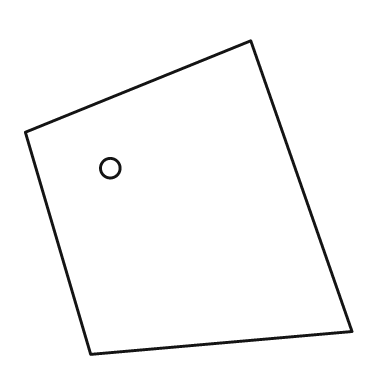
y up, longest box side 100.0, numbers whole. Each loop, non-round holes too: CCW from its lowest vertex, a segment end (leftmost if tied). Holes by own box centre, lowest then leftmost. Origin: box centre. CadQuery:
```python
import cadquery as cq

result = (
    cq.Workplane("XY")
    .moveTo(-30.0, -48.0)
    .lineTo(50.0, -41.0)
    .lineTo(19.0, 48.0)
    .lineTo(-50.0, 20.0)
    .close()
    .moveTo(-24.0, 9.0)
    .circle(3.0)
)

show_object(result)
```